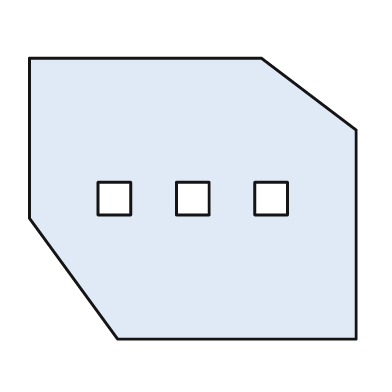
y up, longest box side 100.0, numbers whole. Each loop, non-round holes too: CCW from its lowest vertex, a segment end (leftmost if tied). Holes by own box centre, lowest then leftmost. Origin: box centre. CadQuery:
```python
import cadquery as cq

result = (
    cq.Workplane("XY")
    .moveTo(-23.0, -43.0)
    .lineTo(50.0, -43.0)
    .lineTo(50.0, 21.0)
    .lineTo(21.0, 43.0)
    .lineTo(-50.0, 43.0)
    .lineTo(-50.0, -6.0)
    .close()
    .moveTo(-29.0, -5.0)
    .lineTo(-19.0, -5.0)
    .lineTo(-19.0, 5.0)
    .lineTo(-29.0, 5.0)
    .close()
    .moveTo(-5.0, -5.0)
    .lineTo(5.0, -5.0)
    .lineTo(5.0, 5.0)
    .lineTo(-5.0, 5.0)
    .close()
    .moveTo(19.0, -5.0)
    .lineTo(29.0, -5.0)
    .lineTo(29.0, 5.0)
    .lineTo(19.0, 5.0)
    .close()
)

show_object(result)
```